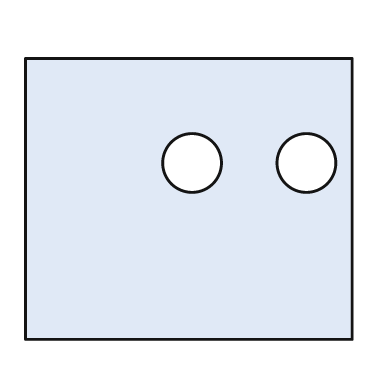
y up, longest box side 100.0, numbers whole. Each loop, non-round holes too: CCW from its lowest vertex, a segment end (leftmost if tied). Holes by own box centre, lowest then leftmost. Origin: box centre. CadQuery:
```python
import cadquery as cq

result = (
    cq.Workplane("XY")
    .moveTo(-50.0, -43.0)
    .lineTo(50.0, -43.0)
    .lineTo(50.0, 43.0)
    .lineTo(-50.0, 43.0)
    .close()
    .moveTo(1.0, 11.0)
    .circle(9.0)
    .moveTo(36.0, 11.0)
    .circle(9.0)
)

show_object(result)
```